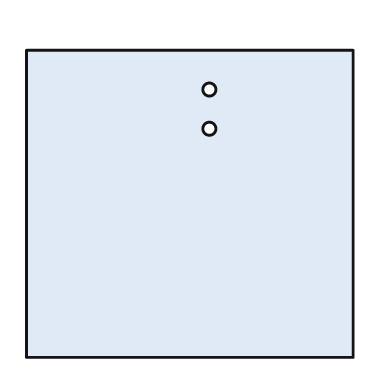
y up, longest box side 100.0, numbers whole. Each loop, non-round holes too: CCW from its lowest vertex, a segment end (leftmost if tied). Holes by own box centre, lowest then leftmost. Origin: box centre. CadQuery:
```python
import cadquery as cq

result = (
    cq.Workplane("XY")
    .moveTo(-50.0, -47.0)
    .lineTo(50.0, -47.0)
    .lineTo(50.0, 47.0)
    .lineTo(-50.0, 47.0)
    .close()
    .moveTo(6.0, 23.0)
    .circle(2.0)
    .moveTo(6.0, 35.0)
    .circle(2.0)
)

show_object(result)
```